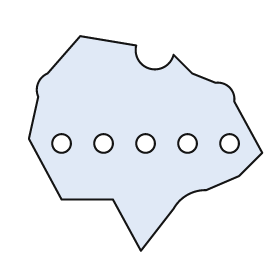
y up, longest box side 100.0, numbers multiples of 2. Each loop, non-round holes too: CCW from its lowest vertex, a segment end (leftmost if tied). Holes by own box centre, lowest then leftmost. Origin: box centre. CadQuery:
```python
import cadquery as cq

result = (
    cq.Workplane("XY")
    .moveTo(-2.0, -46.0)
    .lineTo(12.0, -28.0)
    .threePointArc((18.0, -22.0), (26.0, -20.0))
    .lineTo(40.0, -14.0)
    .lineTo(50.0, -4.0)
    .lineTo(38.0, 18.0)
    .threePointArc((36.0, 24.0), (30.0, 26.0))
    .lineTo(20.0, 30.0)
    .lineTo(12.0, 38.0)
    .threePointArc((2.0, 32.0), (-4.0, 42.0))
    .lineTo(-28.0, 46.0)
    .lineTo(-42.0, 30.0)
    .threePointArc((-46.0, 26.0), (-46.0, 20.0))
    .lineTo(-50.0, 2.0)
    .lineTo(-36.0, -24.0)
    .lineTo(-14.0, -24.0)
    .close()
    .moveTo(-36.0, 0.0)
    .circle(4.0)
    .moveTo(-18.0, 0.0)
    .circle(4.0)
    .moveTo(0.0, 0.0)
    .circle(4.0)
    .moveTo(18.0, 0.0)
    .circle(4.0)
    .moveTo(36.0, 0.0)
    .circle(4.0)
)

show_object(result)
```